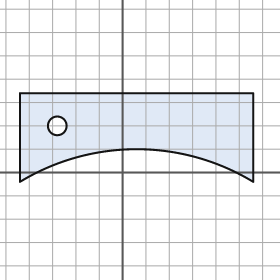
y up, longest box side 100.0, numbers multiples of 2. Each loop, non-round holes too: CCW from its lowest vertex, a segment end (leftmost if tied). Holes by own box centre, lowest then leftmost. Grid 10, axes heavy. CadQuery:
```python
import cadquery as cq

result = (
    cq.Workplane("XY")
    .moveTo(-44.0, -4.0)
    .threePointArc((6.0, 10.0), (56.0, -4.0))
    .lineTo(56.0, 34.0)
    .lineTo(-44.0, 34.0)
    .close()
    .moveTo(-28.0, 20.0)
    .circle(4.0)
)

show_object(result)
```